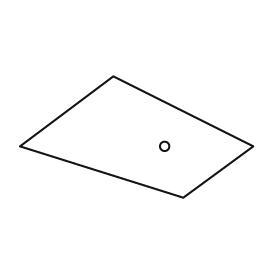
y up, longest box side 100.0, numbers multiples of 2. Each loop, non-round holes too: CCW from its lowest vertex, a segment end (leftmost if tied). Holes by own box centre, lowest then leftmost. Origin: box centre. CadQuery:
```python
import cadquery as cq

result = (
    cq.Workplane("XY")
    .moveTo(20.0, -26.0)
    .lineTo(50.0, -4.0)
    .lineTo(-10.0, 26.0)
    .lineTo(-50.0, -4.0)
    .close()
    .moveTo(12.0, -4.0)
    .circle(2.0)
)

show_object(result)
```